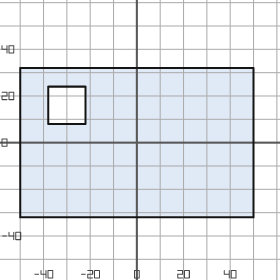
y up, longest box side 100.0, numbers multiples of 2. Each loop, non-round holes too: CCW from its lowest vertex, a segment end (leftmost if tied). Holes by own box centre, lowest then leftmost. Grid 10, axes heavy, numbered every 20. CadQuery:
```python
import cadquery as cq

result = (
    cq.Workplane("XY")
    .moveTo(-50.0, -32.0)
    .lineTo(50.0, -32.0)
    .lineTo(50.0, 32.0)
    .lineTo(-50.0, 32.0)
    .close()
    .moveTo(-38.0, 8.0)
    .lineTo(-22.0, 8.0)
    .lineTo(-22.0, 24.0)
    .lineTo(-38.0, 24.0)
    .close()
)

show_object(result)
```